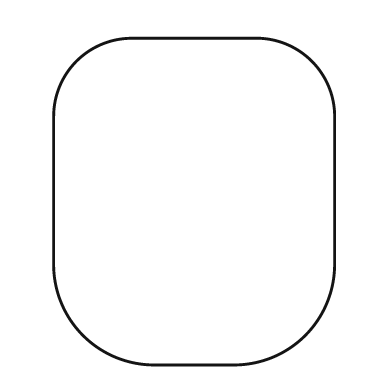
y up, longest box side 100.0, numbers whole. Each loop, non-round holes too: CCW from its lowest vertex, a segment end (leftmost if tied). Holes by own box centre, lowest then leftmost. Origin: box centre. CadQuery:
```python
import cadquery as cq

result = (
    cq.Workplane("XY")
    .moveTo(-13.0, -50.0)
    .lineTo(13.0, -50.0)
    .threePointArc((34.0, -41.0), (43.0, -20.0))
    .lineTo(43.0, 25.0)
    .threePointArc((36.0, 43.0), (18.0, 50.0))
    .lineTo(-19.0, 50.0)
    .threePointArc((-36.0, 43.0), (-43.0, 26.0))
    .lineTo(-43.0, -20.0)
    .threePointArc((-34.0, -41.0), (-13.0, -50.0))
    .close()
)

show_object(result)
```